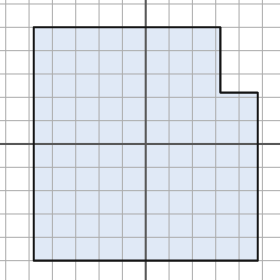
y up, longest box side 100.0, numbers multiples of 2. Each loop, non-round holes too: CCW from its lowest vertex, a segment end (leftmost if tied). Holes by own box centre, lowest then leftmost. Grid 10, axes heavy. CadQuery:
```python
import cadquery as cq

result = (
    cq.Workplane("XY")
    .moveTo(-48.0, -50.0)
    .lineTo(48.0, -50.0)
    .lineTo(48.0, 22.0)
    .lineTo(32.0, 22.0)
    .lineTo(32.0, 50.0)
    .lineTo(-48.0, 50.0)
    .close()
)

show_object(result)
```